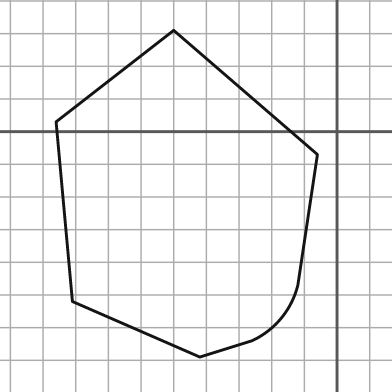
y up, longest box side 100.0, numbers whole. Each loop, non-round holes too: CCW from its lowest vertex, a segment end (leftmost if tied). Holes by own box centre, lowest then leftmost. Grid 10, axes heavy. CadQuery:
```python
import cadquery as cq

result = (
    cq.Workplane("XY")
    .moveTo(-42.0, -69.0)
    .lineTo(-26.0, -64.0)
    .threePointArc((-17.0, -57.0), (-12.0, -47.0))
    .lineTo(-6.0, -7.0)
    .lineTo(-50.0, 31.0)
    .lineTo(-86.0, 3.0)
    .lineTo(-81.0, -52.0)
    .close()
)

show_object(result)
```